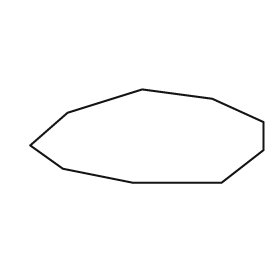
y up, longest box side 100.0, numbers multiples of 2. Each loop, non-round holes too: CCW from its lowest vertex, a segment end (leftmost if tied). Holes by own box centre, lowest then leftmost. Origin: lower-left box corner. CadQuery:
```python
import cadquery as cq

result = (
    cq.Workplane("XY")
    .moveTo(44.0, 0.0)
    .lineTo(82.0, 0.0)
    .lineTo(100.0, 14.0)
    .lineTo(100.0, 26.0)
    .lineTo(78.0, 36.0)
    .lineTo(48.0, 40.0)
    .lineTo(16.0, 30.0)
    .lineTo(0.0, 16.0)
    .lineTo(14.0, 6.0)
    .close()
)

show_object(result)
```